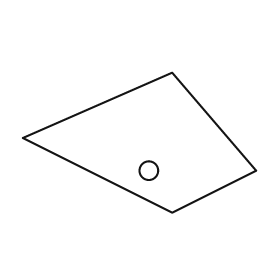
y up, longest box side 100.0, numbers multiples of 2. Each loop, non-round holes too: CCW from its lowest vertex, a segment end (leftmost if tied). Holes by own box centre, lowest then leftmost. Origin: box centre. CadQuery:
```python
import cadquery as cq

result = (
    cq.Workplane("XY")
    .moveTo(14.0, -30.0)
    .lineTo(50.0, -12.0)
    .lineTo(14.0, 30.0)
    .lineTo(-50.0, 2.0)
    .close()
    .moveTo(4.0, -12.0)
    .circle(4.0)
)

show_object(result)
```